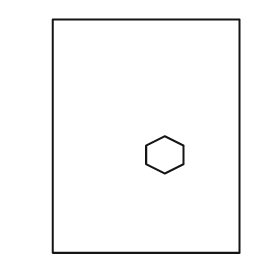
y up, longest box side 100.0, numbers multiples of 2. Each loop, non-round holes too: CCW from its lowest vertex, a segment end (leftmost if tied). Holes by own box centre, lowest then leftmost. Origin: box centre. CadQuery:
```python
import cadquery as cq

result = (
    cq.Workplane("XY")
    .moveTo(-40.0, -50.0)
    .lineTo(40.0, -50.0)
    .lineTo(40.0, 50.0)
    .lineTo(-40.0, 50.0)
    .close()
    .moveTo(8.0, -16.0)
    .lineTo(16.0, -12.0)
    .lineTo(16.0, -4.0)
    .lineTo(8.0, 0.0)
    .lineTo(0.0, -4.0)
    .lineTo(0.0, -12.0)
    .close()
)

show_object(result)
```